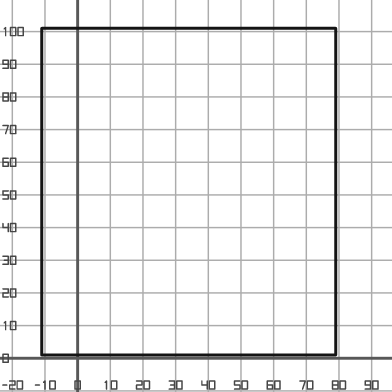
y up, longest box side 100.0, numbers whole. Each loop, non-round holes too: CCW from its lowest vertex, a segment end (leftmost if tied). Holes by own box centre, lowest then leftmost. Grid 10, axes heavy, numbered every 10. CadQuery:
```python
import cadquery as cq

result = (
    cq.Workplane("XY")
    .moveTo(-11.0, 1.0)
    .lineTo(79.0, 1.0)
    .lineTo(79.0, 101.0)
    .lineTo(-11.0, 101.0)
    .close()
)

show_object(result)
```